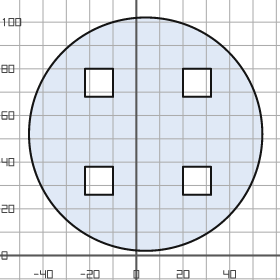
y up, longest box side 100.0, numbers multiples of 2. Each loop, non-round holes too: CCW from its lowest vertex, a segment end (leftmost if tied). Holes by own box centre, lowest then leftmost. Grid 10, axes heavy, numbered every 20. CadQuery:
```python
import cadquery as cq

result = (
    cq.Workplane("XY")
    .moveTo(4.0, 52.0)
    .circle(50.0)
    .moveTo(-22.0, 26.0)
    .lineTo(-10.0, 26.0)
    .lineTo(-10.0, 38.0)
    .lineTo(-22.0, 38.0)
    .close()
    .moveTo(20.0, 26.0)
    .lineTo(32.0, 26.0)
    .lineTo(32.0, 38.0)
    .lineTo(20.0, 38.0)
    .close()
    .moveTo(-22.0, 68.0)
    .lineTo(-10.0, 68.0)
    .lineTo(-10.0, 80.0)
    .lineTo(-22.0, 80.0)
    .close()
    .moveTo(20.0, 68.0)
    .lineTo(32.0, 68.0)
    .lineTo(32.0, 80.0)
    .lineTo(20.0, 80.0)
    .close()
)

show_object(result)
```